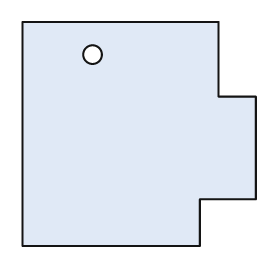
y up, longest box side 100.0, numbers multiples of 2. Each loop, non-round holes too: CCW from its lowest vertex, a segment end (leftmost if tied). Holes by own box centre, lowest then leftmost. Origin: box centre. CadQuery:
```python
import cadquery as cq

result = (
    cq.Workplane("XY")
    .moveTo(-50.0, -48.0)
    .lineTo(26.0, -48.0)
    .lineTo(26.0, -28.0)
    .lineTo(50.0, -28.0)
    .lineTo(50.0, 16.0)
    .lineTo(34.0, 16.0)
    .lineTo(34.0, 48.0)
    .lineTo(-50.0, 48.0)
    .close()
    .moveTo(-20.0, 34.0)
    .circle(4.0)
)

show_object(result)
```